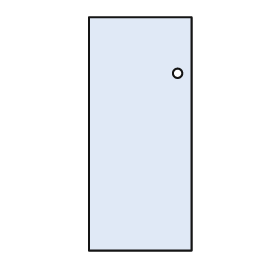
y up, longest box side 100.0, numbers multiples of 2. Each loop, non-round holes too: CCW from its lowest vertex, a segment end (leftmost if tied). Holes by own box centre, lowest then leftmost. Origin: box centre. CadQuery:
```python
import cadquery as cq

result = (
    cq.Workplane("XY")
    .moveTo(-22.0, -50.0)
    .lineTo(22.0, -50.0)
    .lineTo(22.0, 50.0)
    .lineTo(-22.0, 50.0)
    .close()
    .moveTo(16.0, 26.0)
    .circle(2.0)
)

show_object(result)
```